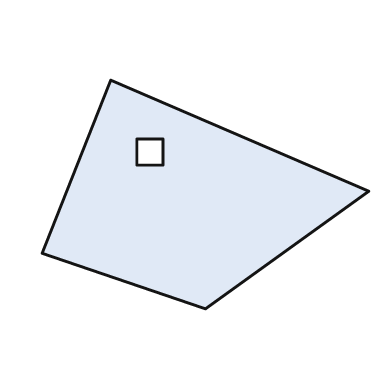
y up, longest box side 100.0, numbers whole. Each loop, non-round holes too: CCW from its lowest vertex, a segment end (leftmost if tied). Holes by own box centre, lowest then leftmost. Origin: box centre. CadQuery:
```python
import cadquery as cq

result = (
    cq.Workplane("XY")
    .moveTo(0.0, -35.0)
    .lineTo(50.0, 1.0)
    .lineTo(-29.0, 35.0)
    .lineTo(-50.0, -18.0)
    .close()
    .moveTo(-21.0, 9.0)
    .lineTo(-13.0, 9.0)
    .lineTo(-13.0, 17.0)
    .lineTo(-21.0, 17.0)
    .close()
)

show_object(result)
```